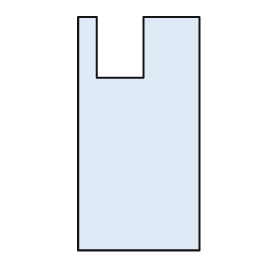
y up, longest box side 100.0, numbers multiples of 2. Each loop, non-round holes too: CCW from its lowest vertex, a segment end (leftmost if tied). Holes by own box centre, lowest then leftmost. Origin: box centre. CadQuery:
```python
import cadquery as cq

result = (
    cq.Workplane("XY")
    .moveTo(-26.0, -50.0)
    .lineTo(26.0, -50.0)
    .lineTo(26.0, 50.0)
    .lineTo(2.0, 50.0)
    .lineTo(2.0, 24.0)
    .lineTo(-18.0, 24.0)
    .lineTo(-18.0, 50.0)
    .lineTo(-26.0, 50.0)
    .close()
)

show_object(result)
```